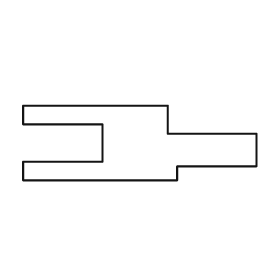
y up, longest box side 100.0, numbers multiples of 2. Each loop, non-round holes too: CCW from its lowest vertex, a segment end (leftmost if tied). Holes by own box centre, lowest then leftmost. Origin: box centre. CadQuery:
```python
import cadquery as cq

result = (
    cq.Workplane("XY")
    .moveTo(-50.0, -16.0)
    .lineTo(16.0, -16.0)
    .lineTo(16.0, -10.0)
    .lineTo(50.0, -10.0)
    .lineTo(50.0, 4.0)
    .lineTo(12.0, 4.0)
    .lineTo(12.0, 16.0)
    .lineTo(-50.0, 16.0)
    .lineTo(-50.0, 8.0)
    .lineTo(-16.0, 8.0)
    .lineTo(-16.0, -8.0)
    .lineTo(-50.0, -8.0)
    .close()
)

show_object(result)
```